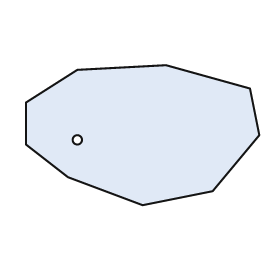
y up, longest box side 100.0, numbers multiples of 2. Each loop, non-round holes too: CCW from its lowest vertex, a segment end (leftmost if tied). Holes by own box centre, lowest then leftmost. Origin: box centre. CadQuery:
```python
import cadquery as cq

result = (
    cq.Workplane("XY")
    .moveTo(0.0, -30.0)
    .lineTo(30.0, -24.0)
    .lineTo(50.0, 0.0)
    .lineTo(46.0, 20.0)
    .lineTo(10.0, 30.0)
    .lineTo(-28.0, 28.0)
    .lineTo(-50.0, 14.0)
    .lineTo(-50.0, -4.0)
    .lineTo(-32.0, -18.0)
    .close()
    .moveTo(-28.0, -2.0)
    .circle(2.0)
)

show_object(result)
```